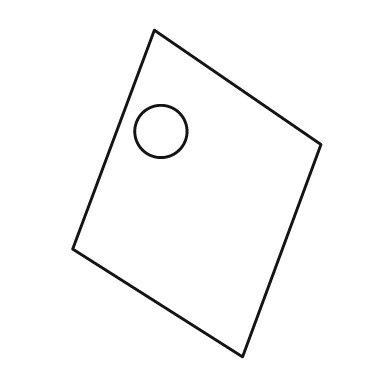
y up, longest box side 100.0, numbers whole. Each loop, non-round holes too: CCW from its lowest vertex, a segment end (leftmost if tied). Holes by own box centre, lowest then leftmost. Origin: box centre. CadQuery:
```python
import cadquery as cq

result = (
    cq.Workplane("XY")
    .moveTo(14.0, -50.0)
    .lineTo(38.0, 15.0)
    .lineTo(-13.0, 50.0)
    .lineTo(-38.0, -17.0)
    .close()
    .moveTo(-11.0, 19.0)
    .circle(8.0)
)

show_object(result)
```